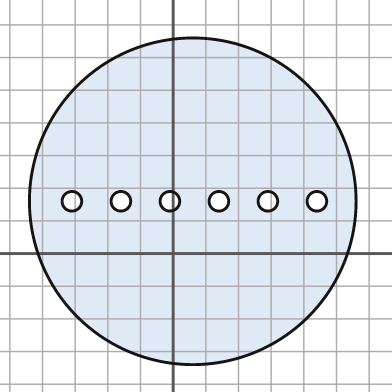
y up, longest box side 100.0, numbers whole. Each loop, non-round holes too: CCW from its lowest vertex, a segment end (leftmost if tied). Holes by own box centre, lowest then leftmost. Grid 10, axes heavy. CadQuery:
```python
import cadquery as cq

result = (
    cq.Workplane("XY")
    .moveTo(6.0, 16.0)
    .circle(50.0)
    .moveTo(-31.0, 16.0)
    .circle(3.0)
    .moveTo(-16.0, 16.0)
    .circle(3.0)
    .moveTo(-1.0, 16.0)
    .circle(3.0)
    .moveTo(14.0, 16.0)
    .circle(3.0)
    .moveTo(29.0, 16.0)
    .circle(3.0)
    .moveTo(44.0, 16.0)
    .circle(3.0)
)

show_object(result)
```